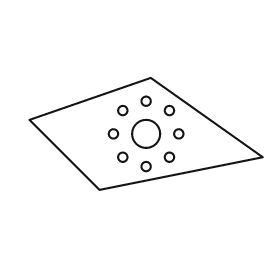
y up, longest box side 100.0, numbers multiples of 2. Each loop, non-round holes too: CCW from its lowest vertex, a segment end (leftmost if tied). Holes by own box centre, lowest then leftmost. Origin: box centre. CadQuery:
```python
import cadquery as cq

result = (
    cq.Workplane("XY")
    .moveTo(-20.0, -24.0)
    .lineTo(50.0, -10.0)
    .lineTo(2.0, 24.0)
    .lineTo(-50.0, 6.0)
    .close()
    .moveTo(0.0, -14.0)
    .circle(2.0)
    .moveTo(-10.0, -10.0)
    .circle(2.0)
    .moveTo(10.0, -10.0)
    .circle(2.0)
    .moveTo(-14.0, 0.0)
    .circle(2.0)
    .moveTo(0.0, 0.0)
    .circle(6.0)
    .moveTo(14.0, 0.0)
    .circle(2.0)
    .moveTo(-10.0, 10.0)
    .circle(2.0)
    .moveTo(10.0, 10.0)
    .circle(2.0)
    .moveTo(0.0, 14.0)
    .circle(2.0)
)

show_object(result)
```